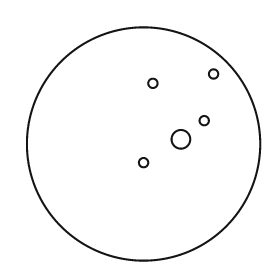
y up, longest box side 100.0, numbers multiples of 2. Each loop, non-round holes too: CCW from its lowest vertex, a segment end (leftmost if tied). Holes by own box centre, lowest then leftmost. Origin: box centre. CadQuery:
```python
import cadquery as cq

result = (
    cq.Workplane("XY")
    .moveTo(0.0, 0.0)
    .circle(50.0)
    .moveTo(0.0, -8.0)
    .circle(2.0)
    .moveTo(16.0, 2.0)
    .circle(4.0)
    .moveTo(26.0, 10.0)
    .circle(2.0)
    .moveTo(4.0, 26.0)
    .circle(2.0)
    .moveTo(30.0, 30.0)
    .circle(2.0)
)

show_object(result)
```